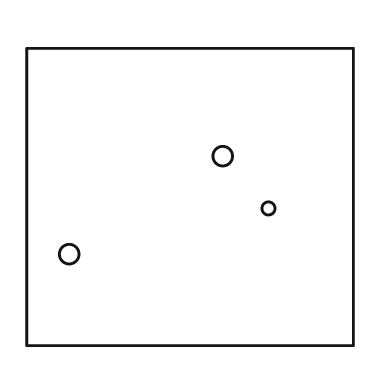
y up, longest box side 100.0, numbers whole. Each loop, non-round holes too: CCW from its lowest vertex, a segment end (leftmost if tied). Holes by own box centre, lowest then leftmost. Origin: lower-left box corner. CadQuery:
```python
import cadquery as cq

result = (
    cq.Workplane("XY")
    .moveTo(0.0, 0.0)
    .lineTo(100.0, 0.0)
    .lineTo(100.0, 91.0)
    .lineTo(0.0, 91.0)
    .close()
    .moveTo(13.0, 28.0)
    .circle(3.0)
    .moveTo(74.0, 42.0)
    .circle(2.0)
    .moveTo(60.0, 58.0)
    .circle(3.0)
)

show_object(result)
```